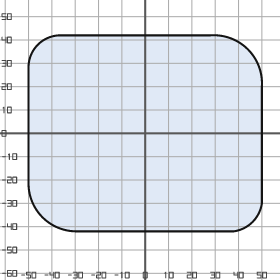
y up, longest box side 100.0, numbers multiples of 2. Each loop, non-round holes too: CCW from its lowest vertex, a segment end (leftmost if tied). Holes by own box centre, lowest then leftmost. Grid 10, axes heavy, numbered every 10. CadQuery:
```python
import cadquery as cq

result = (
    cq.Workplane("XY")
    .moveTo(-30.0, -42.0)
    .lineTo(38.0, -42.0)
    .threePointArc((46.0, -38.0), (50.0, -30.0))
    .lineTo(50.0, 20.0)
    .threePointArc((44.0, 36.0), (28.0, 42.0))
    .lineTo(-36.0, 42.0)
    .threePointArc((-46.0, 38.0), (-50.0, 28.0))
    .lineTo(-50.0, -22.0)
    .threePointArc((-44.0, -36.0), (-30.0, -42.0))
    .close()
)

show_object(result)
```